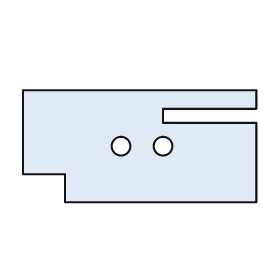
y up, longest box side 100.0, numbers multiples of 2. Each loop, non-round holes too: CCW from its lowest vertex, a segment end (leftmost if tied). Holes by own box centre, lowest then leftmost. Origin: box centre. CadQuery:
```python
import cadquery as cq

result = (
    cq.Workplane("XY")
    .moveTo(-32.0, -24.0)
    .lineTo(50.0, -24.0)
    .lineTo(50.0, 10.0)
    .lineTo(10.0, 10.0)
    .lineTo(10.0, 16.0)
    .lineTo(50.0, 16.0)
    .lineTo(50.0, 24.0)
    .lineTo(-50.0, 24.0)
    .lineTo(-50.0, -12.0)
    .lineTo(-32.0, -12.0)
    .close()
    .moveTo(-8.0, 0.0)
    .circle(4.0)
    .moveTo(10.0, 0.0)
    .circle(4.0)
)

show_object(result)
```